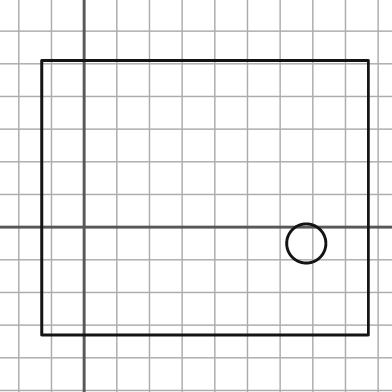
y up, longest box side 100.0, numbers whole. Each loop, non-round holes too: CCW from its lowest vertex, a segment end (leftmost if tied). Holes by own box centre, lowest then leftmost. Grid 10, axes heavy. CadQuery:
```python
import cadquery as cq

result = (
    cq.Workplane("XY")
    .moveTo(-13.0, -33.0)
    .lineTo(87.0, -33.0)
    .lineTo(87.0, 51.0)
    .lineTo(-13.0, 51.0)
    .close()
    .moveTo(68.0, -5.0)
    .circle(6.0)
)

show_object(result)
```